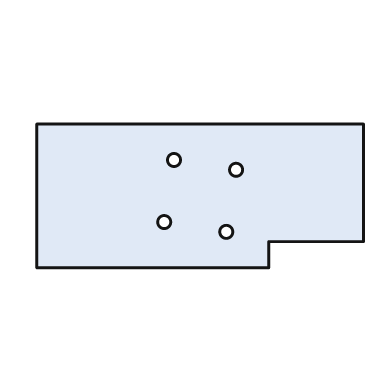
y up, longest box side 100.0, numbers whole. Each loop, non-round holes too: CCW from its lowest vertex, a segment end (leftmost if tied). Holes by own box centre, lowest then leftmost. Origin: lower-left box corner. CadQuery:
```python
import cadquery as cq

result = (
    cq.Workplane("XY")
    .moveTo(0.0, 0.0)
    .lineTo(71.0, 0.0)
    .lineTo(71.0, 8.0)
    .lineTo(100.0, 8.0)
    .lineTo(100.0, 44.0)
    .lineTo(0.0, 44.0)
    .close()
    .moveTo(58.0, 11.0)
    .circle(2.0)
    .moveTo(39.0, 14.0)
    .circle(2.0)
    .moveTo(61.0, 30.0)
    .circle(2.0)
    .moveTo(42.0, 33.0)
    .circle(2.0)
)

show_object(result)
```